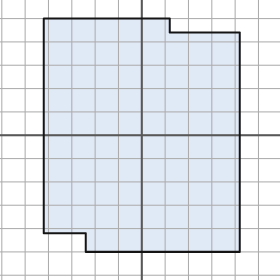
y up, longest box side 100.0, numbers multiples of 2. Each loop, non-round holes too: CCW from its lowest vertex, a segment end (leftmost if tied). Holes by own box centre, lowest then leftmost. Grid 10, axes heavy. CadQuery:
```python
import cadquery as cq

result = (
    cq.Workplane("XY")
    .moveTo(-24.0, -50.0)
    .lineTo(42.0, -50.0)
    .lineTo(42.0, 44.0)
    .lineTo(12.0, 44.0)
    .lineTo(12.0, 50.0)
    .lineTo(-42.0, 50.0)
    .lineTo(-42.0, -42.0)
    .lineTo(-24.0, -42.0)
    .close()
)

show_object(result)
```